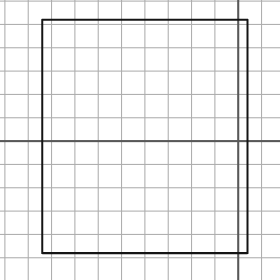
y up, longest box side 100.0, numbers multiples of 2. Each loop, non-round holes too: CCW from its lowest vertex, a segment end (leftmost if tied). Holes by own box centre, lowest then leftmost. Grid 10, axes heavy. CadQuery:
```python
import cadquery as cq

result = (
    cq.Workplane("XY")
    .moveTo(-84.0, -48.0)
    .lineTo(4.0, -48.0)
    .lineTo(4.0, 52.0)
    .lineTo(-84.0, 52.0)
    .close()
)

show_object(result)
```